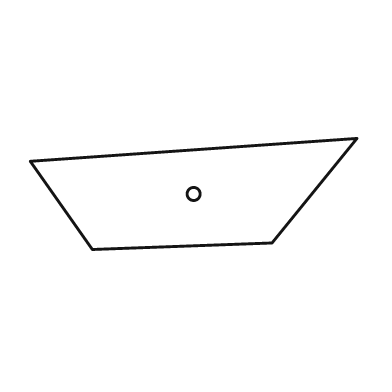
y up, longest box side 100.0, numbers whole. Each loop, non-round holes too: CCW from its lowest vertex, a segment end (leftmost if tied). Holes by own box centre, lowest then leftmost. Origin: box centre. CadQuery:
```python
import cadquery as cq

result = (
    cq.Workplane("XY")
    .moveTo(-31.0, -17.0)
    .lineTo(24.0, -15.0)
    .lineTo(50.0, 17.0)
    .lineTo(-50.0, 10.0)
    .close()
    .moveTo(0.0, 0.0)
    .circle(2.0)
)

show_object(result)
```